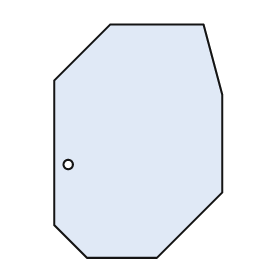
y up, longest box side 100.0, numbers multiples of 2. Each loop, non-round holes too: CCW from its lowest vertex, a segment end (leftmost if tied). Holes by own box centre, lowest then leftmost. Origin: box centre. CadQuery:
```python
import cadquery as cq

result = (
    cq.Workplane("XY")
    .moveTo(-22.0, -50.0)
    .lineTo(8.0, -50.0)
    .lineTo(36.0, -22.0)
    .lineTo(36.0, 20.0)
    .lineTo(28.0, 50.0)
    .lineTo(-12.0, 50.0)
    .lineTo(-36.0, 26.0)
    .lineTo(-36.0, -36.0)
    .close()
    .moveTo(-30.0, -10.0)
    .circle(2.0)
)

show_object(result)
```